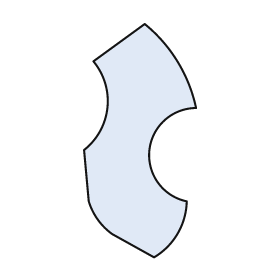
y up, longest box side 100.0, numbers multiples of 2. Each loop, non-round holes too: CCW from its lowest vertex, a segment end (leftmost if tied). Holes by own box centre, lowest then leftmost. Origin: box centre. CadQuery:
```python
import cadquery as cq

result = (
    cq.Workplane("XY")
    .moveTo(6.0, -50.0)
    .threePointArc((16.0, -40.0), (20.0, -26.0))
    .threePointArc((4.0, -4.0), (24.0, 14.0))
    .threePointArc((16.0, 34.0), (2.0, 50.0))
    .lineTo(-20.0, 34.0)
    .threePointArc((-14.0, 14.0), (-24.0, -4.0))
    .lineTo(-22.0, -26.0)
    .threePointArc((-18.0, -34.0), (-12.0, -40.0))
    .close()
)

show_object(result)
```